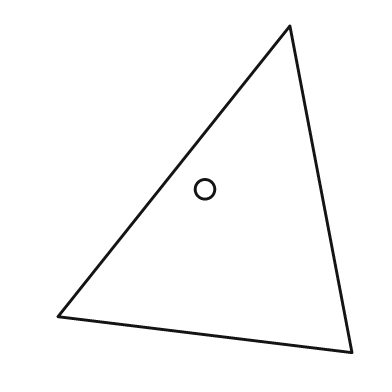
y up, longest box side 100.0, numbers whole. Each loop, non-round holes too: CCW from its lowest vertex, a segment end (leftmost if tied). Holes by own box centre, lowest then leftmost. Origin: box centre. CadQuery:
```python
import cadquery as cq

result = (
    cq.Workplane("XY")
    .moveTo(45.0, -50.0)
    .lineTo(26.0, 50.0)
    .lineTo(-45.0, -39.0)
    .close()
    .moveTo(0.0, 0.0)
    .circle(3.0)
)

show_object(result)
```